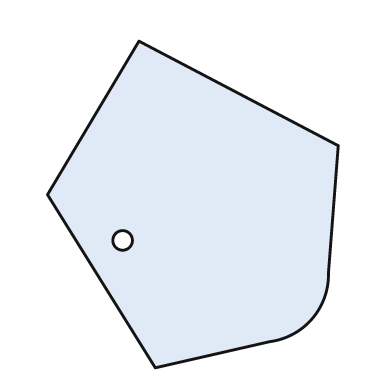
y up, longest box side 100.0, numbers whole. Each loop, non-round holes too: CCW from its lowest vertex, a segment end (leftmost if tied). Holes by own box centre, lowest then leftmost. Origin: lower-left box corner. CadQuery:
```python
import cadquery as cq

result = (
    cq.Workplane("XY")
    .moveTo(33.0, 0.0)
    .lineTo(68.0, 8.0)
    .threePointArc((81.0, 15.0), (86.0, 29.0))
    .lineTo(89.0, 68.0)
    .lineTo(28.0, 100.0)
    .lineTo(0.0, 53.0)
    .close()
    .moveTo(23.0, 39.0)
    .circle(3.0)
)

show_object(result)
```